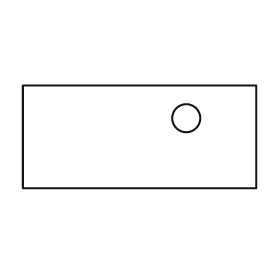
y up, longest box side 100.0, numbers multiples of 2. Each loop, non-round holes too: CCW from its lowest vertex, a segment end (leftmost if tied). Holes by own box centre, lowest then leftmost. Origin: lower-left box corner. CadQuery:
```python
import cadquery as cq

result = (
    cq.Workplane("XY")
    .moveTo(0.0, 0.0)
    .lineTo(100.0, 0.0)
    .lineTo(100.0, 44.0)
    .lineTo(0.0, 44.0)
    .close()
    .moveTo(70.0, 30.0)
    .circle(6.0)
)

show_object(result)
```